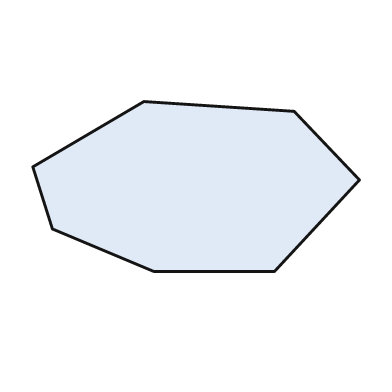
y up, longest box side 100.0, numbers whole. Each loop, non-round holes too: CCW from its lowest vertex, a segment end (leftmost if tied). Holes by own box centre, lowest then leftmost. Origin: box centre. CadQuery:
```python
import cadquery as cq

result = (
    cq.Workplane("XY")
    .moveTo(-13.0, -26.0)
    .lineTo(24.0, -26.0)
    .lineTo(50.0, 2.0)
    .lineTo(30.0, 23.0)
    .lineTo(-16.0, 26.0)
    .lineTo(-50.0, 6.0)
    .lineTo(-44.0, -13.0)
    .close()
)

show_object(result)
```